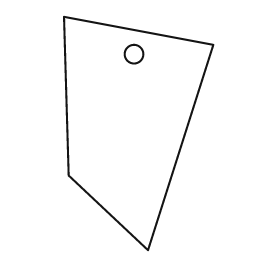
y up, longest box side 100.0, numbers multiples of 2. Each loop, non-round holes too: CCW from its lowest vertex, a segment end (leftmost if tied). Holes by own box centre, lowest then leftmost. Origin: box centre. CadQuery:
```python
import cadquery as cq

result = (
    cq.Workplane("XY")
    .moveTo(4.0, -50.0)
    .lineTo(32.0, 38.0)
    .lineTo(-32.0, 50.0)
    .lineTo(-30.0, -18.0)
    .close()
    .moveTo(-2.0, 34.0)
    .circle(4.0)
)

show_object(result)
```